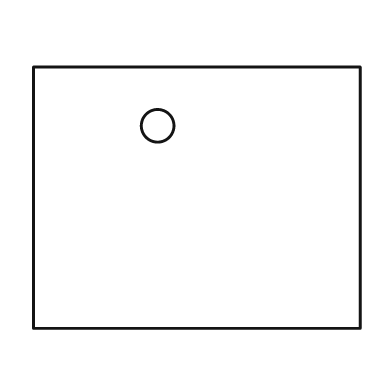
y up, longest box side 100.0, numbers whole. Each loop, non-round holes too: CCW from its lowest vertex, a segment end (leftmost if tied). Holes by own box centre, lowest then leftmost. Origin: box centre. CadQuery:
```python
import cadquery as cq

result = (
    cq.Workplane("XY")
    .moveTo(-50.0, -40.0)
    .lineTo(50.0, -40.0)
    .lineTo(50.0, 40.0)
    .lineTo(-50.0, 40.0)
    .close()
    .moveTo(-12.0, 22.0)
    .circle(5.0)
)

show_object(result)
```